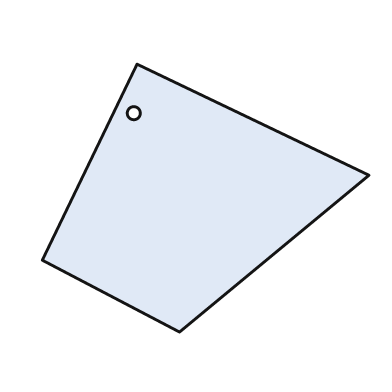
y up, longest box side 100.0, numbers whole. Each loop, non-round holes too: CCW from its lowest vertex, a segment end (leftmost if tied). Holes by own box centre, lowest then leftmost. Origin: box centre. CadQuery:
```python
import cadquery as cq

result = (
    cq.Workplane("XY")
    .moveTo(-8.0, -41.0)
    .lineTo(50.0, 7.0)
    .lineTo(-21.0, 41.0)
    .lineTo(-50.0, -19.0)
    .close()
    .moveTo(-22.0, 26.0)
    .circle(2.0)
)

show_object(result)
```